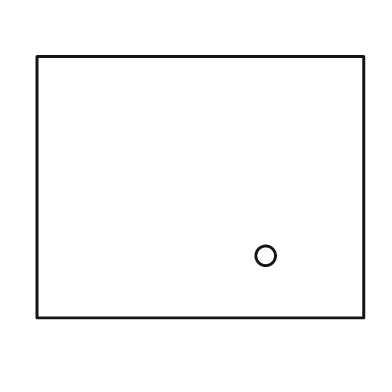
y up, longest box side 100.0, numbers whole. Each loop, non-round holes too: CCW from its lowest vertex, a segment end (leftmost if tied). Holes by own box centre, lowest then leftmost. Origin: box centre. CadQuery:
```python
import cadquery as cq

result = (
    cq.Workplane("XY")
    .moveTo(-50.0, -40.0)
    .lineTo(50.0, -40.0)
    .lineTo(50.0, 40.0)
    .lineTo(-50.0, 40.0)
    .close()
    .moveTo(20.0, -21.0)
    .circle(3.0)
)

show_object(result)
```